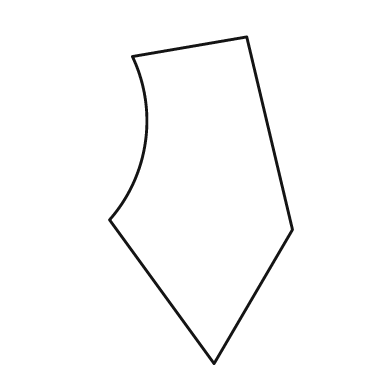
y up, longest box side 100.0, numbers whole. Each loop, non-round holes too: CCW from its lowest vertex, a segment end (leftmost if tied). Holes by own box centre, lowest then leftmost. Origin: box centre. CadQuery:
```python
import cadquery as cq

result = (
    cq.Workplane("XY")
    .moveTo(4.0, -50.0)
    .lineTo(28.0, -9.0)
    .lineTo(14.0, 50.0)
    .lineTo(-21.0, 44.0)
    .threePointArc((-17.0, 18.0), (-28.0, -6.0))
    .close()
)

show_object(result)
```